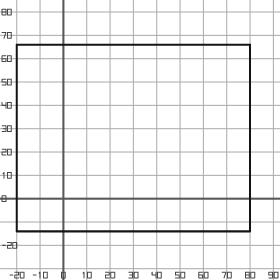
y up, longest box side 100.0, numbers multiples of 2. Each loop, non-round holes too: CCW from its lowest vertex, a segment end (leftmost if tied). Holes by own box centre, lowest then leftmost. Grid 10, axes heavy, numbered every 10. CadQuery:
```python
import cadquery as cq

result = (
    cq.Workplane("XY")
    .moveTo(-20.0, -14.0)
    .lineTo(80.0, -14.0)
    .lineTo(80.0, 66.0)
    .lineTo(-20.0, 66.0)
    .close()
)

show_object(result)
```